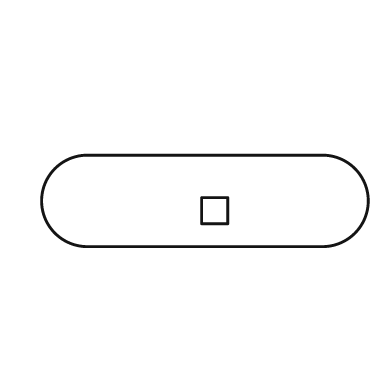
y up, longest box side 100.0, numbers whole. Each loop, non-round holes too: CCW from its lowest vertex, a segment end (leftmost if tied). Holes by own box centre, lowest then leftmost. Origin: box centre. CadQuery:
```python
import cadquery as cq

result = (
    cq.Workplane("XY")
    .moveTo(-36.0, -14.0)
    .lineTo(36.0, -14.0)
    .threePointArc((50.0, 0.0), (36.0, 14.0))
    .lineTo(-36.0, 14.0)
    .threePointArc((-50.0, 0.0), (-36.0, -14.0))
    .close()
    .moveTo(-1.0, -7.0)
    .lineTo(7.0, -7.0)
    .lineTo(7.0, 1.0)
    .lineTo(-1.0, 1.0)
    .close()
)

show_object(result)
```